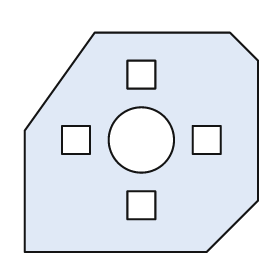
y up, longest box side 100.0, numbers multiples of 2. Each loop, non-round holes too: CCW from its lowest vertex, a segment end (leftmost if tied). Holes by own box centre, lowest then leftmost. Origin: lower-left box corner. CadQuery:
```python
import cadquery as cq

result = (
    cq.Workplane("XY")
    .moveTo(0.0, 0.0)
    .lineTo(78.0, 0.0)
    .lineTo(100.0, 22.0)
    .lineTo(100.0, 82.0)
    .lineTo(88.0, 94.0)
    .lineTo(30.0, 94.0)
    .lineTo(0.0, 52.0)
    .close()
    .moveTo(44.0, 14.0)
    .lineTo(56.0, 14.0)
    .lineTo(56.0, 26.0)
    .lineTo(44.0, 26.0)
    .close()
    .moveTo(16.0, 42.0)
    .lineTo(28.0, 42.0)
    .lineTo(28.0, 54.0)
    .lineTo(16.0, 54.0)
    .close()
    .moveTo(50.0, 48.0)
    .circle(14.0)
    .moveTo(72.0, 42.0)
    .lineTo(84.0, 42.0)
    .lineTo(84.0, 54.0)
    .lineTo(72.0, 54.0)
    .close()
    .moveTo(44.0, 70.0)
    .lineTo(56.0, 70.0)
    .lineTo(56.0, 82.0)
    .lineTo(44.0, 82.0)
    .close()
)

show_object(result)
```